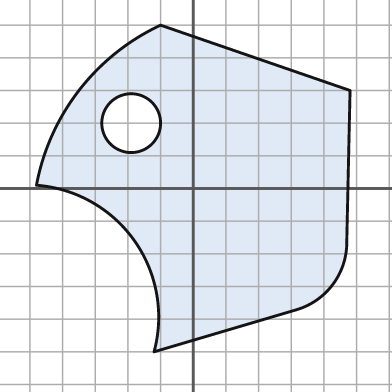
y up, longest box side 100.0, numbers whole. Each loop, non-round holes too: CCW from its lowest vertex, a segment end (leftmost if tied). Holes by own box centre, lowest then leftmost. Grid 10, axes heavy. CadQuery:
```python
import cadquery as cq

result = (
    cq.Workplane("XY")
    .moveTo(-12.0, -50.0)
    .lineTo(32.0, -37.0)
    .threePointArc((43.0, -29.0), (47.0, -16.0))
    .lineTo(48.0, 30.0)
    .lineTo(-10.0, 50.0)
    .threePointArc((-35.0, 30.0), (-48.0, 1.0))
    .threePointArc((-18.0, -16.0), (-12.0, -50.0))
    .close()
    .moveTo(-19.0, 20.0)
    .circle(9.0)
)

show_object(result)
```